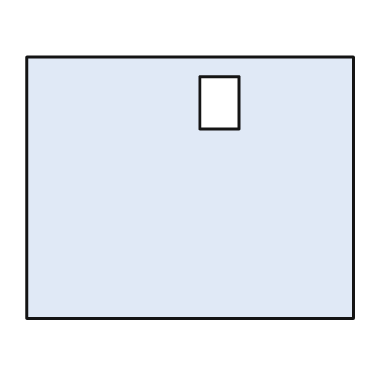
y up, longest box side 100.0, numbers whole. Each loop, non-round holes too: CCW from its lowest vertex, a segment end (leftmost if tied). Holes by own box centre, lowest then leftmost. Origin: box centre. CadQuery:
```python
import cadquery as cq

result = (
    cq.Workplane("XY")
    .moveTo(-50.0, -40.0)
    .lineTo(50.0, -40.0)
    .lineTo(50.0, 40.0)
    .lineTo(-50.0, 40.0)
    .close()
    .moveTo(3.0, 18.0)
    .lineTo(15.0, 18.0)
    .lineTo(15.0, 34.0)
    .lineTo(3.0, 34.0)
    .close()
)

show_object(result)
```